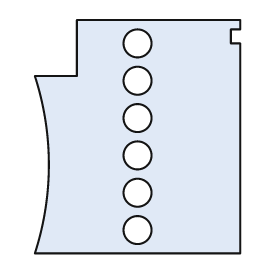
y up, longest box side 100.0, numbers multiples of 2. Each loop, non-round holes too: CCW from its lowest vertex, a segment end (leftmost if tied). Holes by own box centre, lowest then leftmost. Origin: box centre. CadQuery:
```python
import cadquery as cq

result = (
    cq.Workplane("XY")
    .moveTo(-44.0, -50.0)
    .lineTo(44.0, -50.0)
    .lineTo(44.0, 40.0)
    .lineTo(40.0, 40.0)
    .lineTo(40.0, 46.0)
    .lineTo(44.0, 46.0)
    .lineTo(44.0, 50.0)
    .lineTo(-26.0, 50.0)
    .lineTo(-26.0, 26.0)
    .lineTo(-44.0, 26.0)
    .threePointArc((-38.0, -12.0), (-44.0, -50.0))
    .close()
    .moveTo(0.0, -40.0)
    .circle(6.0)
    .moveTo(0.0, -24.0)
    .circle(6.0)
    .moveTo(0.0, -8.0)
    .circle(6.0)
    .moveTo(0.0, 8.0)
    .circle(6.0)
    .moveTo(0.0, 24.0)
    .circle(6.0)
    .moveTo(0.0, 40.0)
    .circle(6.0)
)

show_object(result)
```